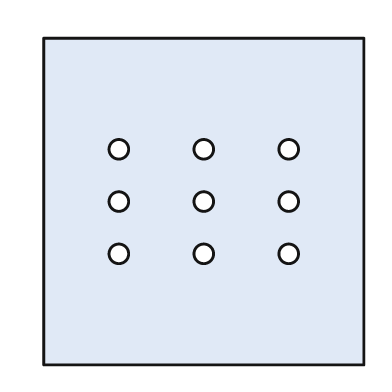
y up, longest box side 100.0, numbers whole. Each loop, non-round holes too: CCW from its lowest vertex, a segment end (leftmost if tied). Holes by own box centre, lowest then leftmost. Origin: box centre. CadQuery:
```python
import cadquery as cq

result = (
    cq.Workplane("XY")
    .moveTo(-49.0, -50.0)
    .lineTo(49.0, -50.0)
    .lineTo(49.0, 50.0)
    .lineTo(-49.0, 50.0)
    .close()
    .moveTo(-26.0, -16.0)
    .circle(3.0)
    .moveTo(0.0, -16.0)
    .circle(3.0)
    .moveTo(26.0, -16.0)
    .circle(3.0)
    .moveTo(-26.0, 0.0)
    .circle(3.0)
    .moveTo(0.0, 0.0)
    .circle(3.0)
    .moveTo(26.0, 0.0)
    .circle(3.0)
    .moveTo(-26.0, 16.0)
    .circle(3.0)
    .moveTo(0.0, 16.0)
    .circle(3.0)
    .moveTo(26.0, 16.0)
    .circle(3.0)
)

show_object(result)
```